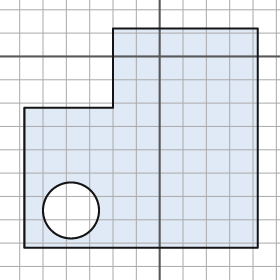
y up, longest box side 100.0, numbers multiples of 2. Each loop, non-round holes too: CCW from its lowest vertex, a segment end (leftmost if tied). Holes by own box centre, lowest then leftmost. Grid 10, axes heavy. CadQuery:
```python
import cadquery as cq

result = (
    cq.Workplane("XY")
    .moveTo(-58.0, -82.0)
    .lineTo(42.0, -82.0)
    .lineTo(42.0, 12.0)
    .lineTo(-20.0, 12.0)
    .lineTo(-20.0, -22.0)
    .lineTo(-58.0, -22.0)
    .close()
    .moveTo(-38.0, -66.0)
    .circle(12.0)
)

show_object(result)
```